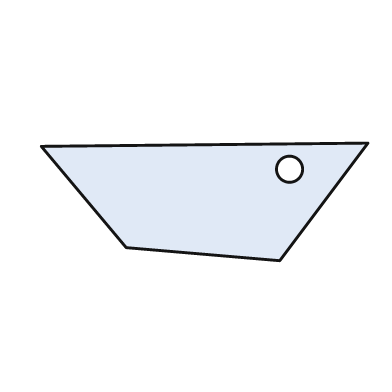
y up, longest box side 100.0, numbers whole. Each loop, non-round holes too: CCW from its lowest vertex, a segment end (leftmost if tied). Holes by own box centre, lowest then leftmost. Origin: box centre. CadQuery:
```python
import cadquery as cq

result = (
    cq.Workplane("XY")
    .moveTo(23.0, -18.0)
    .lineTo(50.0, 18.0)
    .lineTo(-50.0, 17.0)
    .lineTo(-24.0, -14.0)
    .close()
    .moveTo(26.0, 10.0)
    .circle(4.0)
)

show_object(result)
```